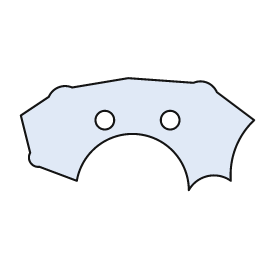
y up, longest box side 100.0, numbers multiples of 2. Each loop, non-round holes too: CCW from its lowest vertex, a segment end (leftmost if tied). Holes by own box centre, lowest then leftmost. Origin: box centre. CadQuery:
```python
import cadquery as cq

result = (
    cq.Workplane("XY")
    .moveTo(22.0, -24.0)
    .threePointArc((30.0, -18.0), (40.0, -20.0))
    .threePointArc((42.0, -6.0), (50.0, 6.0))
    .lineTo(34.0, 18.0)
    .threePointArc((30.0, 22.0), (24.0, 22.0))
    .lineTo(-4.0, 24.0)
    .lineTo(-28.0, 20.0)
    .threePointArc((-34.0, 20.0), (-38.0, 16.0))
    .lineTo(-50.0, 8.0)
    .lineTo(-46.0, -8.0)
    .threePointArc((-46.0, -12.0), (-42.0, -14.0))
    .lineTo(-26.0, -20.0)
    .threePointArc((0.0, 0.0), (22.0, -24.0))
    .close()
    .moveTo(-14.0, 6.0)
    .circle(4.0)
    .moveTo(14.0, 6.0)
    .circle(4.0)
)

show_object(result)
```